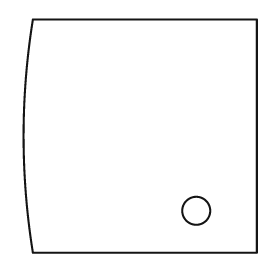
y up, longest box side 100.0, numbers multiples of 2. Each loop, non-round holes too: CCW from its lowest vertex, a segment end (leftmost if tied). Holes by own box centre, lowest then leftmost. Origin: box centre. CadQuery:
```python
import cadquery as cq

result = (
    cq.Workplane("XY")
    .moveTo(-46.0, -50.0)
    .lineTo(50.0, -50.0)
    .lineTo(50.0, 50.0)
    .lineTo(-46.0, 50.0)
    .threePointArc((-50.0, 0.0), (-46.0, -50.0))
    .close()
    .moveTo(24.0, -32.0)
    .circle(6.0)
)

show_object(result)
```